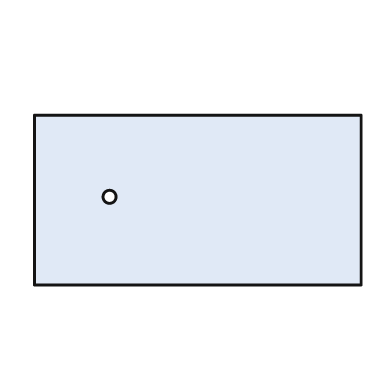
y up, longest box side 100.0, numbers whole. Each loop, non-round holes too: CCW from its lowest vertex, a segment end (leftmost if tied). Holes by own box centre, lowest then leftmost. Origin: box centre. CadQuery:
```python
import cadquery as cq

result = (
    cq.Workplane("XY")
    .moveTo(-50.0, -26.0)
    .lineTo(50.0, -26.0)
    .lineTo(50.0, 26.0)
    .lineTo(-50.0, 26.0)
    .close()
    .moveTo(-27.0, 1.0)
    .circle(2.0)
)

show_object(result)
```